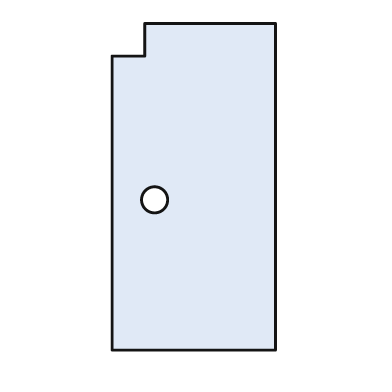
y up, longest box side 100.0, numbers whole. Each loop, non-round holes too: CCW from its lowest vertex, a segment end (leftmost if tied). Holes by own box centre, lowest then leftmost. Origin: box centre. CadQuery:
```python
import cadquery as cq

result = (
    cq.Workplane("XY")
    .moveTo(-25.0, -50.0)
    .lineTo(25.0, -50.0)
    .lineTo(25.0, 50.0)
    .lineTo(-15.0, 50.0)
    .lineTo(-15.0, 40.0)
    .lineTo(-25.0, 40.0)
    .close()
    .moveTo(-12.0, -4.0)
    .circle(4.0)
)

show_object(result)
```